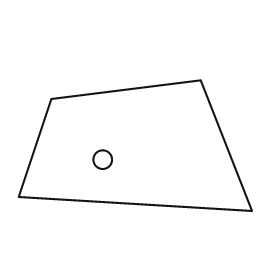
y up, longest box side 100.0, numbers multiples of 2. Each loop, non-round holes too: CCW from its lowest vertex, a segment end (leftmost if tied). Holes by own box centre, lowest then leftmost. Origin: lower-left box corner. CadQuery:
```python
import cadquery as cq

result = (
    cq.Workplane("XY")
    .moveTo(100.0, 0.0)
    .lineTo(78.0, 56.0)
    .lineTo(14.0, 48.0)
    .lineTo(0.0, 6.0)
    .close()
    .moveTo(36.0, 22.0)
    .circle(4.0)
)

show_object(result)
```